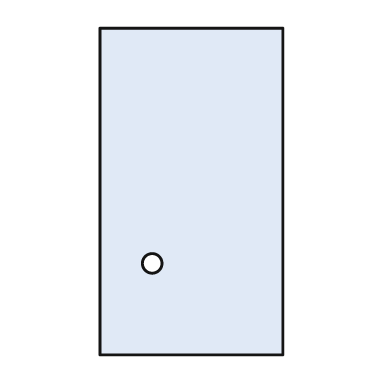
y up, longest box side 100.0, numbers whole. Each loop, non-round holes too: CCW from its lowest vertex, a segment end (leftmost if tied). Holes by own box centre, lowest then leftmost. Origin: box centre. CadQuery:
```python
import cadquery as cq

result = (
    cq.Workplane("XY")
    .moveTo(-28.0, -50.0)
    .lineTo(28.0, -50.0)
    .lineTo(28.0, 50.0)
    .lineTo(-28.0, 50.0)
    .close()
    .moveTo(-12.0, -22.0)
    .circle(3.0)
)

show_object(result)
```